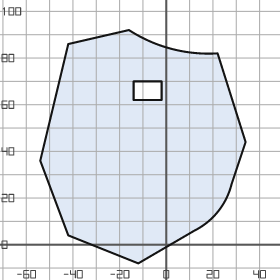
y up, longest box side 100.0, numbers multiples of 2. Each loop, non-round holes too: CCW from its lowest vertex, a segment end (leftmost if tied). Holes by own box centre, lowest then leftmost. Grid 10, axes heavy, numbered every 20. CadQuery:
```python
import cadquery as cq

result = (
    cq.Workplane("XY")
    .moveTo(-12.0, -8.0)
    .lineTo(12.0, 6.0)
    .threePointArc((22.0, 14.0), (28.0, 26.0))
    .lineTo(34.0, 44.0)
    .lineTo(22.0, 82.0)
    .threePointArc((2.0, 84.0), (-16.0, 92.0))
    .lineTo(-42.0, 86.0)
    .lineTo(-54.0, 36.0)
    .lineTo(-42.0, 4.0)
    .close()
    .moveTo(-14.0, 62.0)
    .lineTo(-2.0, 62.0)
    .lineTo(-2.0, 70.0)
    .lineTo(-14.0, 70.0)
    .close()
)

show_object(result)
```